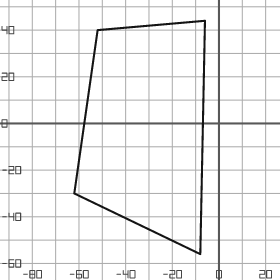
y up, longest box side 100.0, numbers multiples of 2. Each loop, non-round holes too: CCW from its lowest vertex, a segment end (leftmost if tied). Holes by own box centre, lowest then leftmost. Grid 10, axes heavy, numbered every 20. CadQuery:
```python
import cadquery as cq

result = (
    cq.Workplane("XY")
    .moveTo(-8.0, -56.0)
    .lineTo(-6.0, 44.0)
    .lineTo(-52.0, 40.0)
    .lineTo(-62.0, -30.0)
    .close()
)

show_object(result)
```